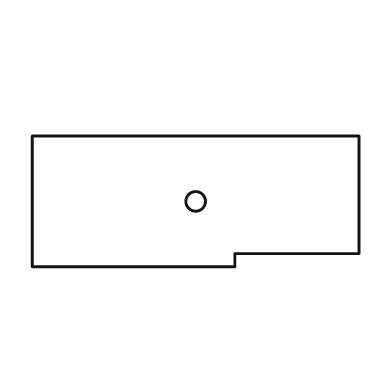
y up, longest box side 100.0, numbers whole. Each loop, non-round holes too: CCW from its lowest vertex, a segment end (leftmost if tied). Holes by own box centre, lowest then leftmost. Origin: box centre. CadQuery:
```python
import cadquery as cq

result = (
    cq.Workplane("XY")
    .moveTo(-50.0, -20.0)
    .lineTo(12.0, -20.0)
    .lineTo(12.0, -16.0)
    .lineTo(50.0, -16.0)
    .lineTo(50.0, 20.0)
    .lineTo(-50.0, 20.0)
    .close()
    .moveTo(0.0, 0.0)
    .circle(3.0)
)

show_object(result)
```